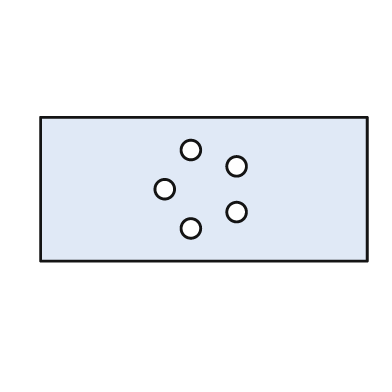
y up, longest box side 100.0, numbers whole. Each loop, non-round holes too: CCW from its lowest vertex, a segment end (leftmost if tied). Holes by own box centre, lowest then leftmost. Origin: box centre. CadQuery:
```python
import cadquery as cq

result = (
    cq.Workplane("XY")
    .moveTo(-50.0, -22.0)
    .lineTo(50.0, -22.0)
    .lineTo(50.0, 22.0)
    .lineTo(-50.0, 22.0)
    .close()
    .moveTo(-4.0, -12.0)
    .circle(3.0)
    .moveTo(10.0, -7.0)
    .circle(3.0)
    .moveTo(-12.0, 0.0)
    .circle(3.0)
    .moveTo(10.0, 7.0)
    .circle(3.0)
    .moveTo(-4.0, 12.0)
    .circle(3.0)
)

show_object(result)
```